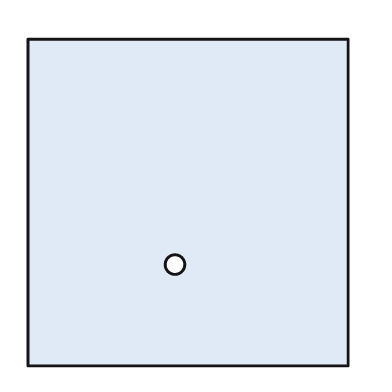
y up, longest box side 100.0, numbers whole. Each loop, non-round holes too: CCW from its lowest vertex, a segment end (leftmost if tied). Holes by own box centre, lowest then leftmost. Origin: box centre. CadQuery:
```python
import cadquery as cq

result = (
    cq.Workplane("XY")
    .moveTo(-49.0, -50.0)
    .lineTo(49.0, -50.0)
    .lineTo(49.0, 50.0)
    .lineTo(-49.0, 50.0)
    .close()
    .moveTo(-4.0, -19.0)
    .circle(3.0)
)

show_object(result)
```